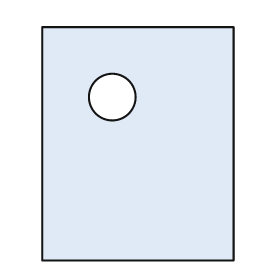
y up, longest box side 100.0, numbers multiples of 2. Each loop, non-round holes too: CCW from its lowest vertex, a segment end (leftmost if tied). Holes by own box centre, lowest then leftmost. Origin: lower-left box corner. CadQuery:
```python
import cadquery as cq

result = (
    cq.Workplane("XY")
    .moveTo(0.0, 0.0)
    .lineTo(82.0, 0.0)
    .lineTo(82.0, 100.0)
    .lineTo(0.0, 100.0)
    .close()
    .moveTo(30.0, 70.0)
    .circle(10.0)
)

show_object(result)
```